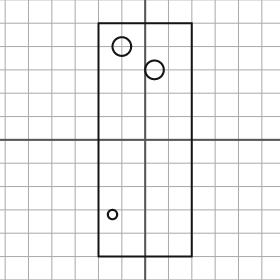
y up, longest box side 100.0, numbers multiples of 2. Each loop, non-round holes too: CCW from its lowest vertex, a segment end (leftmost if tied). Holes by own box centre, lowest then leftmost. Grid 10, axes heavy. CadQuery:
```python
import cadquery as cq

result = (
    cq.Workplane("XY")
    .moveTo(-20.0, -50.0)
    .lineTo(20.0, -50.0)
    .lineTo(20.0, 50.0)
    .lineTo(-20.0, 50.0)
    .close()
    .moveTo(-14.0, -32.0)
    .circle(2.0)
    .moveTo(4.0, 30.0)
    .circle(4.0)
    .moveTo(-10.0, 40.0)
    .circle(4.0)
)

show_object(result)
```